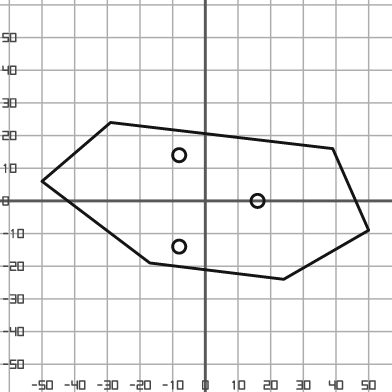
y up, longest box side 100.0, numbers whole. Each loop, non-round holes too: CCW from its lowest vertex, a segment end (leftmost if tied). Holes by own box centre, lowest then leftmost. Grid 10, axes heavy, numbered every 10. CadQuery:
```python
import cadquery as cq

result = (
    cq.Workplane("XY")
    .moveTo(24.0, -24.0)
    .lineTo(50.0, -9.0)
    .lineTo(39.0, 16.0)
    .lineTo(-29.0, 24.0)
    .lineTo(-50.0, 6.0)
    .lineTo(-17.0, -19.0)
    .close()
    .moveTo(-8.0, -14.0)
    .circle(2.0)
    .moveTo(16.0, 0.0)
    .circle(2.0)
    .moveTo(-8.0, 14.0)
    .circle(2.0)
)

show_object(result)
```